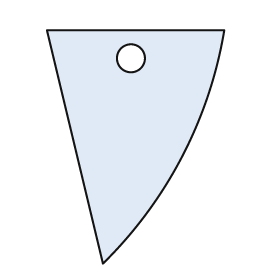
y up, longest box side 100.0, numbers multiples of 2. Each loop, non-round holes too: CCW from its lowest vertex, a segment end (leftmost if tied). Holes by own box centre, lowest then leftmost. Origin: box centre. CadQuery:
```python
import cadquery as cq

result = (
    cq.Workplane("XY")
    .moveTo(-14.0, -50.0)
    .threePointArc((20.0, -4.0), (38.0, 50.0))
    .lineTo(-38.0, 50.0)
    .close()
    .moveTo(-2.0, 38.0)
    .circle(6.0)
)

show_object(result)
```